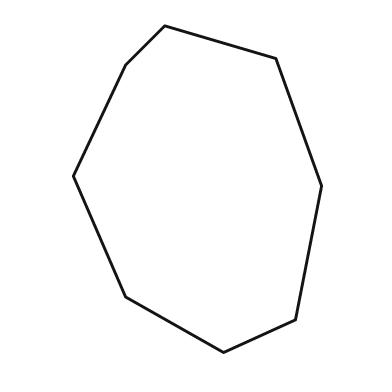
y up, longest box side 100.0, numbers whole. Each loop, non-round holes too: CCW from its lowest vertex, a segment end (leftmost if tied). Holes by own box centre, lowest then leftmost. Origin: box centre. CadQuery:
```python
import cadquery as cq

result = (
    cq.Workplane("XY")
    .moveTo(8.0, -50.0)
    .lineTo(30.0, -40.0)
    .lineTo(38.0, 1.0)
    .lineTo(24.0, 40.0)
    .lineTo(-10.0, 50.0)
    .lineTo(-22.0, 38.0)
    .lineTo(-38.0, 4.0)
    .lineTo(-22.0, -33.0)
    .close()
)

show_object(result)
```